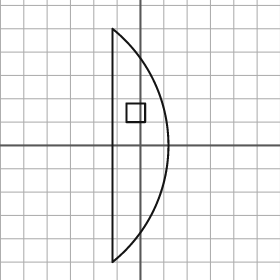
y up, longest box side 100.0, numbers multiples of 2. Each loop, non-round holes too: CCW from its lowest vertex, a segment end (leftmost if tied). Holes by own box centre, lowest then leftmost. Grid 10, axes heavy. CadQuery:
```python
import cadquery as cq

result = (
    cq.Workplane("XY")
    .moveTo(-12.0, -50.0)
    .threePointArc((12.0, 0.0), (-12.0, 50.0))
    .close()
    .moveTo(-6.0, 10.0)
    .lineTo(2.0, 10.0)
    .lineTo(2.0, 18.0)
    .lineTo(-6.0, 18.0)
    .close()
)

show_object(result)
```